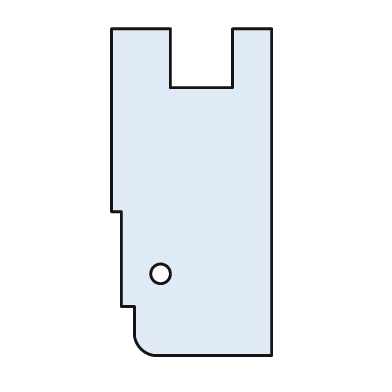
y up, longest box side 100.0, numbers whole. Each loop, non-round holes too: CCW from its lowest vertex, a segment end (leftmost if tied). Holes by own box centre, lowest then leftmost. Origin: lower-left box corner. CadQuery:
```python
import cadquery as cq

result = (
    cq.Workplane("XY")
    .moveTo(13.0, 0.0)
    .lineTo(49.0, 0.0)
    .lineTo(49.0, 100.0)
    .lineTo(37.0, 100.0)
    .lineTo(37.0, 82.0)
    .lineTo(18.0, 82.0)
    .lineTo(18.0, 100.0)
    .lineTo(0.0, 100.0)
    .lineTo(0.0, 44.0)
    .lineTo(3.0, 44.0)
    .lineTo(3.0, 15.0)
    .lineTo(7.0, 15.0)
    .lineTo(7.0, 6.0)
    .threePointArc((9.0, 2.0), (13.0, 0.0))
    .close()
    .moveTo(15.0, 25.0)
    .circle(3.0)
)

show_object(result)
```